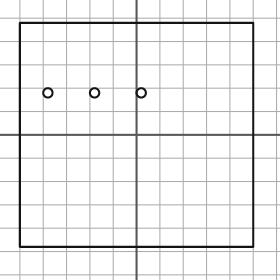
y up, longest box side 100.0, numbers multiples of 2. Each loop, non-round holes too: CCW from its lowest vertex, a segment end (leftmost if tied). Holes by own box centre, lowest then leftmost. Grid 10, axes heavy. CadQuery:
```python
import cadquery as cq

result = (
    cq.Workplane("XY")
    .moveTo(-50.0, -48.0)
    .lineTo(50.0, -48.0)
    .lineTo(50.0, 48.0)
    .lineTo(-50.0, 48.0)
    .close()
    .moveTo(-38.0, 18.0)
    .circle(2.0)
    .moveTo(-18.0, 18.0)
    .circle(2.0)
    .moveTo(2.0, 18.0)
    .circle(2.0)
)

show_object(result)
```